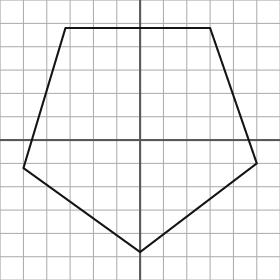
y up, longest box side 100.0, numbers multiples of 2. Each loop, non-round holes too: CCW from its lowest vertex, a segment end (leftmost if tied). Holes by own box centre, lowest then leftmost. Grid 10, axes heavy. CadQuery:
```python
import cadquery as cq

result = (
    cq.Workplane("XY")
    .moveTo(0.0, -48.0)
    .lineTo(50.0, -10.0)
    .lineTo(30.0, 48.0)
    .lineTo(-32.0, 48.0)
    .lineTo(-50.0, -12.0)
    .close()
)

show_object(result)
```